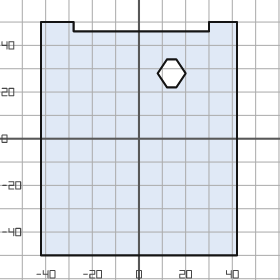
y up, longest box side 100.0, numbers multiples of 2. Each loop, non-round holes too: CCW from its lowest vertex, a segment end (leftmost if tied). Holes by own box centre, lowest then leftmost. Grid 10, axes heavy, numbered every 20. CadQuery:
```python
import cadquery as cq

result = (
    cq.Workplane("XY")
    .moveTo(-42.0, -50.0)
    .lineTo(42.0, -50.0)
    .lineTo(42.0, 50.0)
    .lineTo(30.0, 50.0)
    .lineTo(30.0, 46.0)
    .lineTo(-28.0, 46.0)
    .lineTo(-28.0, 50.0)
    .lineTo(-42.0, 50.0)
    .close()
    .moveTo(12.0, 22.0)
    .lineTo(16.0, 22.0)
    .lineTo(20.0, 28.0)
    .lineTo(16.0, 34.0)
    .lineTo(12.0, 34.0)
    .lineTo(8.0, 28.0)
    .close()
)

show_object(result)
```